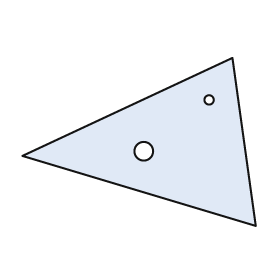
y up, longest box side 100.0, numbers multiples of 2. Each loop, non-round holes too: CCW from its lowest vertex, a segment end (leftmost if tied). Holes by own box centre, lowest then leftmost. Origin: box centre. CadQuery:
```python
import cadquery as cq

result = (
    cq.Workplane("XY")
    .moveTo(50.0, -36.0)
    .lineTo(40.0, 36.0)
    .lineTo(-50.0, -6.0)
    .close()
    .moveTo(2.0, -4.0)
    .circle(4.0)
    .moveTo(30.0, 18.0)
    .circle(2.0)
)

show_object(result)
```